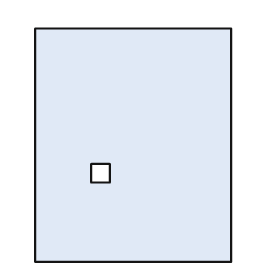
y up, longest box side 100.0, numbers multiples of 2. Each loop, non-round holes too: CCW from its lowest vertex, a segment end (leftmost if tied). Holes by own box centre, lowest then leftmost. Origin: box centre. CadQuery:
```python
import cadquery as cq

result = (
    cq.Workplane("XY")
    .moveTo(-42.0, -50.0)
    .lineTo(42.0, -50.0)
    .lineTo(42.0, 50.0)
    .lineTo(-42.0, 50.0)
    .close()
    .moveTo(-18.0, -16.0)
    .lineTo(-10.0, -16.0)
    .lineTo(-10.0, -8.0)
    .lineTo(-18.0, -8.0)
    .close()
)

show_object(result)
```